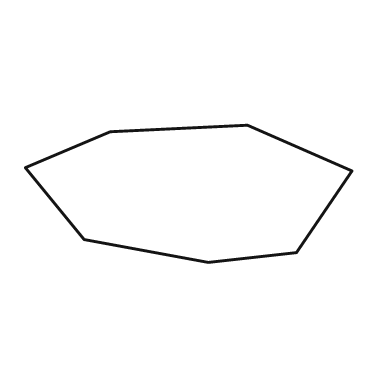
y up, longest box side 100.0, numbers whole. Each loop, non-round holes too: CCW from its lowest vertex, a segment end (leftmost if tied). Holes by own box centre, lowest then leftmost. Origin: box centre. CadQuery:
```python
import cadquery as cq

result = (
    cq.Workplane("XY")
    .moveTo(6.0, -21.0)
    .lineTo(33.0, -18.0)
    .lineTo(50.0, 7.0)
    .lineTo(18.0, 21.0)
    .lineTo(-24.0, 19.0)
    .lineTo(-50.0, 8.0)
    .lineTo(-32.0, -14.0)
    .close()
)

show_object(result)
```